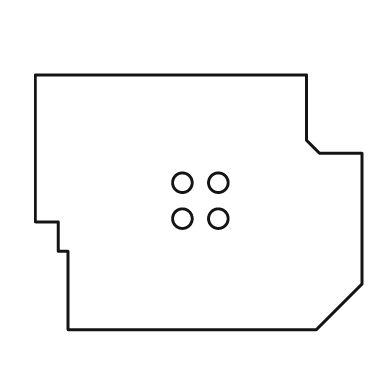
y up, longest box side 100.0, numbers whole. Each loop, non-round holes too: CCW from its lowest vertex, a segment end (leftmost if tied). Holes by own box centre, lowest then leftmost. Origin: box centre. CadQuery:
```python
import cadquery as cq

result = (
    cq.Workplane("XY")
    .moveTo(-40.0, -39.0)
    .lineTo(36.0, -39.0)
    .lineTo(50.0, -25.0)
    .lineTo(50.0, 15.0)
    .lineTo(37.0, 15.0)
    .lineTo(33.0, 19.0)
    .lineTo(33.0, 39.0)
    .lineTo(-50.0, 39.0)
    .lineTo(-50.0, -6.0)
    .lineTo(-43.0, -6.0)
    .lineTo(-43.0, -15.0)
    .lineTo(-40.0, -15.0)
    .close()
    .moveTo(-5.0, -5.0)
    .circle(3.0)
    .moveTo(6.0, -5.0)
    .circle(3.0)
    .moveTo(-5.0, 6.0)
    .circle(3.0)
    .moveTo(6.0, 6.0)
    .circle(3.0)
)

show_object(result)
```